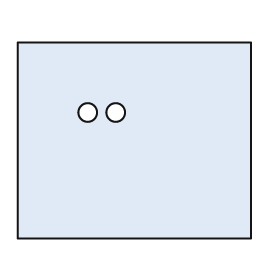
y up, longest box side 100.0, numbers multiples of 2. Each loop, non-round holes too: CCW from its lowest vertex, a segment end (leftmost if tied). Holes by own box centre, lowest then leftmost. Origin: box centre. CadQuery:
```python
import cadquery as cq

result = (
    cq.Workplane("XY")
    .moveTo(-50.0, -42.0)
    .lineTo(50.0, -42.0)
    .lineTo(50.0, 42.0)
    .lineTo(-50.0, 42.0)
    .close()
    .moveTo(-20.0, 12.0)
    .circle(4.0)
    .moveTo(-8.0, 12.0)
    .circle(4.0)
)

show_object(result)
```